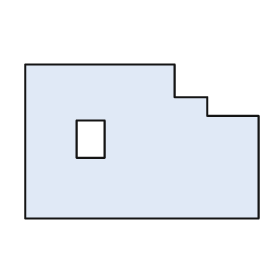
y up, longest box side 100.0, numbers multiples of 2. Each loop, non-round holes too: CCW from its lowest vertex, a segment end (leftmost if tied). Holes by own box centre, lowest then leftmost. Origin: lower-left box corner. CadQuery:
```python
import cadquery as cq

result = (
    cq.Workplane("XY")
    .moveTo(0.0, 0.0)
    .lineTo(100.0, 0.0)
    .lineTo(100.0, 44.0)
    .lineTo(78.0, 44.0)
    .lineTo(78.0, 52.0)
    .lineTo(64.0, 52.0)
    .lineTo(64.0, 66.0)
    .lineTo(0.0, 66.0)
    .close()
    .moveTo(22.0, 26.0)
    .lineTo(34.0, 26.0)
    .lineTo(34.0, 42.0)
    .lineTo(22.0, 42.0)
    .close()
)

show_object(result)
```